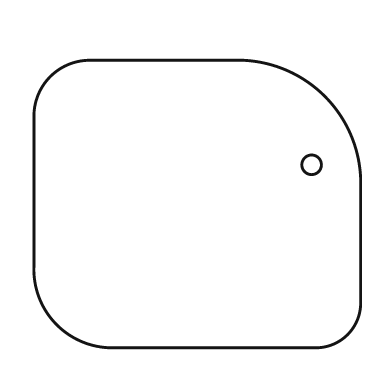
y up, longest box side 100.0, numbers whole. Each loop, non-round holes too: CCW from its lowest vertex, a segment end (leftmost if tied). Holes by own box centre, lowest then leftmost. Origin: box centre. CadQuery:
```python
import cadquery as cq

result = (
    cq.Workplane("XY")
    .moveTo(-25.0, -44.0)
    .lineTo(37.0, -44.0)
    .threePointArc((46.0, -40.0), (50.0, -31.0))
    .lineTo(50.0, 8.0)
    .threePointArc((39.0, 33.0), (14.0, 44.0))
    .lineTo(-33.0, 44.0)
    .threePointArc((-45.0, 39.0), (-50.0, 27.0))
    .lineTo(-50.0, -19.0)
    .threePointArc((-43.0, -37.0), (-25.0, -44.0))
    .close()
    .moveTo(35.0, 12.0)
    .circle(3.0)
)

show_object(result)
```